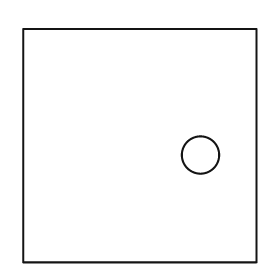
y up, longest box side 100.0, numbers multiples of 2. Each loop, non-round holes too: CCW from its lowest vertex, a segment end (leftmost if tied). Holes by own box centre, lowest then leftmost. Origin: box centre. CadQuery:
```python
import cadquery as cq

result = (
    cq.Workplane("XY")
    .moveTo(-50.0, -50.0)
    .lineTo(50.0, -50.0)
    .lineTo(50.0, 50.0)
    .lineTo(-50.0, 50.0)
    .close()
    .moveTo(26.0, -4.0)
    .circle(8.0)
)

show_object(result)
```